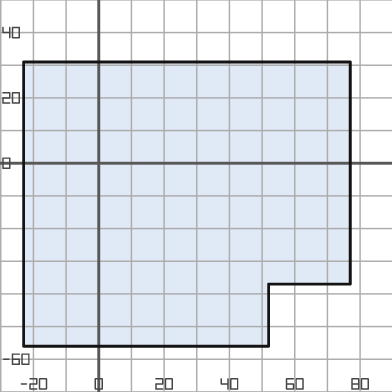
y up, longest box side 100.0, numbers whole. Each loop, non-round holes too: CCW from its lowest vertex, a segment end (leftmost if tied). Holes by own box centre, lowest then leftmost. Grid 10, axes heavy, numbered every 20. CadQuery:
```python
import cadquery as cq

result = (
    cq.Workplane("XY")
    .moveTo(-23.0, -56.0)
    .lineTo(52.0, -56.0)
    .lineTo(52.0, -37.0)
    .lineTo(77.0, -37.0)
    .lineTo(77.0, 31.0)
    .lineTo(-23.0, 31.0)
    .close()
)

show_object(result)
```